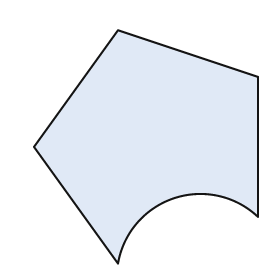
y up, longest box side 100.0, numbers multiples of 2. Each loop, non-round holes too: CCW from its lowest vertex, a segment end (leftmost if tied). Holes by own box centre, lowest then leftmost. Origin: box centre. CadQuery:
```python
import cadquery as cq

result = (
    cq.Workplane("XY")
    .moveTo(-12.0, -50.0)
    .threePointArc((12.0, -22.0), (48.0, -30.0))
    .lineTo(48.0, 30.0)
    .lineTo(-12.0, 50.0)
    .lineTo(-48.0, 0.0)
    .close()
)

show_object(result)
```